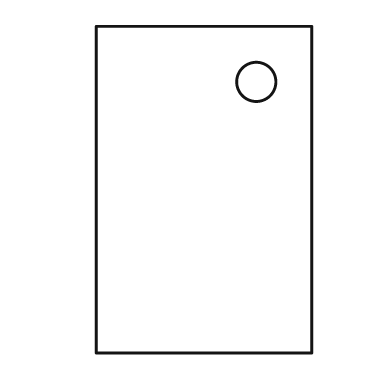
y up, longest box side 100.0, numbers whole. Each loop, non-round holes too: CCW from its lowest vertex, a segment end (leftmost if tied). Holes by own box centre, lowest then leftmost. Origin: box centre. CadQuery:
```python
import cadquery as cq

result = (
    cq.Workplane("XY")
    .moveTo(-33.0, -50.0)
    .lineTo(33.0, -50.0)
    .lineTo(33.0, 50.0)
    .lineTo(-33.0, 50.0)
    .close()
    .moveTo(16.0, 33.0)
    .circle(6.0)
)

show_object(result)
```